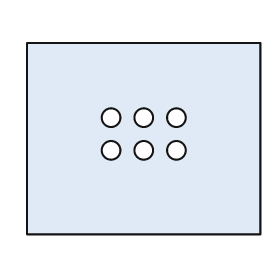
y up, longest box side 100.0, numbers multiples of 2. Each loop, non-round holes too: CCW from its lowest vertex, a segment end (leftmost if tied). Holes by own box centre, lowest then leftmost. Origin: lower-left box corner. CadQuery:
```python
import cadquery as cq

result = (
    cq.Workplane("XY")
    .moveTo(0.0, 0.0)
    .lineTo(100.0, 0.0)
    .lineTo(100.0, 82.0)
    .lineTo(0.0, 82.0)
    .close()
    .moveTo(36.0, 36.0)
    .circle(4.0)
    .moveTo(50.0, 36.0)
    .circle(4.0)
    .moveTo(64.0, 36.0)
    .circle(4.0)
    .moveTo(36.0, 50.0)
    .circle(4.0)
    .moveTo(50.0, 50.0)
    .circle(4.0)
    .moveTo(64.0, 50.0)
    .circle(4.0)
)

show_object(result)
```